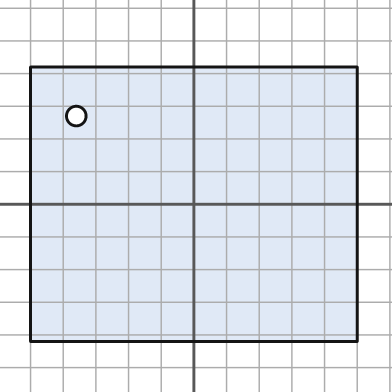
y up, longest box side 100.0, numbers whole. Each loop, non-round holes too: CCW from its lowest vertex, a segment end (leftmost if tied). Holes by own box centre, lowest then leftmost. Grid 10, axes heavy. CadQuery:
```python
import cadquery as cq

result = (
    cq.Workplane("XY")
    .moveTo(-50.0, -42.0)
    .lineTo(50.0, -42.0)
    .lineTo(50.0, 42.0)
    .lineTo(-50.0, 42.0)
    .close()
    .moveTo(-36.0, 27.0)
    .circle(3.0)
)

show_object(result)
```